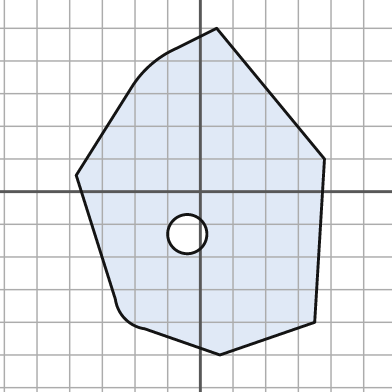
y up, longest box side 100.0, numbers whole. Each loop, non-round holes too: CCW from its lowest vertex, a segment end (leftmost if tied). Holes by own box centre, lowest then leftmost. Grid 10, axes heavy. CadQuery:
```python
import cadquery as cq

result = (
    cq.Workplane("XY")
    .moveTo(6.0, -50.0)
    .lineTo(35.0, -40.0)
    .lineTo(38.0, 10.0)
    .lineTo(5.0, 50.0)
    .lineTo(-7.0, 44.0)
    .threePointArc((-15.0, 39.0), (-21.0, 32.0))
    .lineTo(-38.0, 5.0)
    .lineTo(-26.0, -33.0)
    .threePointArc((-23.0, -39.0), (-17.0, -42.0))
    .close()
    .moveTo(-4.0, -13.0)
    .circle(6.0)
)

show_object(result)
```